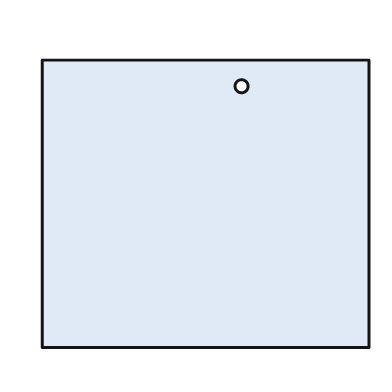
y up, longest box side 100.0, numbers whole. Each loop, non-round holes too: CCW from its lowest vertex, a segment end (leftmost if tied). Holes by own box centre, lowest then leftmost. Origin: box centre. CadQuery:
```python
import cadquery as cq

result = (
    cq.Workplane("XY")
    .moveTo(-50.0, -44.0)
    .lineTo(50.0, -44.0)
    .lineTo(50.0, 44.0)
    .lineTo(-50.0, 44.0)
    .close()
    .moveTo(11.0, 36.0)
    .circle(2.0)
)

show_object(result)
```